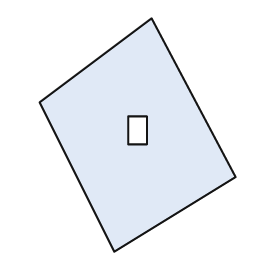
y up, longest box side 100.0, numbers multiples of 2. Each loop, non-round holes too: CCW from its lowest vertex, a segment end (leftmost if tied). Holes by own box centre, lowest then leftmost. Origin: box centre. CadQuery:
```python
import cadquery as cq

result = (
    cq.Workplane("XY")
    .moveTo(-10.0, -50.0)
    .lineTo(42.0, -18.0)
    .lineTo(6.0, 50.0)
    .lineTo(-42.0, 14.0)
    .close()
    .moveTo(-4.0, -4.0)
    .lineTo(4.0, -4.0)
    .lineTo(4.0, 8.0)
    .lineTo(-4.0, 8.0)
    .close()
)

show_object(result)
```